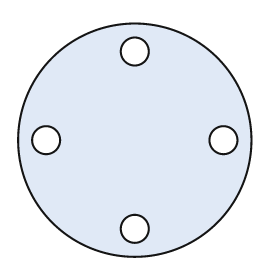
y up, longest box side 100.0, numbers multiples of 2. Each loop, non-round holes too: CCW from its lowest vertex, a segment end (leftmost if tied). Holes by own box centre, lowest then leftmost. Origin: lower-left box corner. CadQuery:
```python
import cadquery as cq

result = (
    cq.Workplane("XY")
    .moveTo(50.0, 50.0)
    .circle(50.0)
    .moveTo(50.0, 12.0)
    .circle(6.0)
    .moveTo(12.0, 50.0)
    .circle(6.0)
    .moveTo(88.0, 50.0)
    .circle(6.0)
    .moveTo(50.0, 88.0)
    .circle(6.0)
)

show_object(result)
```